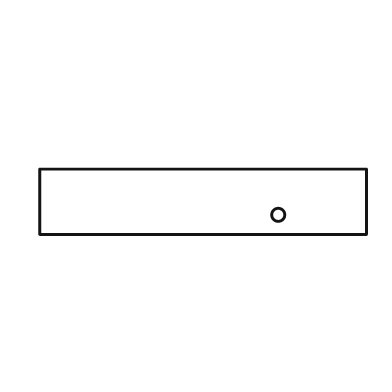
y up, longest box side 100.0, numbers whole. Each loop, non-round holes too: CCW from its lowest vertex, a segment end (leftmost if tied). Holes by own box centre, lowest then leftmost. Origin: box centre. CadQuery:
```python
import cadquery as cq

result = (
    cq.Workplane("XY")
    .moveTo(-50.0, -10.0)
    .lineTo(50.0, -10.0)
    .lineTo(50.0, 10.0)
    .lineTo(-50.0, 10.0)
    .close()
    .moveTo(23.0, -4.0)
    .circle(2.0)
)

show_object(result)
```